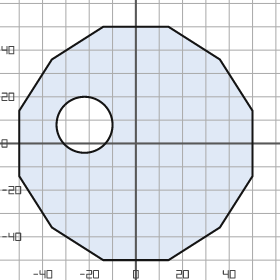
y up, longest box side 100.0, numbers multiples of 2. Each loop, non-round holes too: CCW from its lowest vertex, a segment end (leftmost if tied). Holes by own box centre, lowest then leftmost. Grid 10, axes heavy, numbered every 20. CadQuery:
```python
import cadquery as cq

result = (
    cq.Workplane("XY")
    .moveTo(-14.0, -50.0)
    .lineTo(14.0, -50.0)
    .lineTo(36.0, -36.0)
    .lineTo(50.0, -14.0)
    .lineTo(50.0, 14.0)
    .lineTo(36.0, 36.0)
    .lineTo(14.0, 50.0)
    .lineTo(-14.0, 50.0)
    .lineTo(-36.0, 36.0)
    .lineTo(-50.0, 14.0)
    .lineTo(-50.0, -14.0)
    .lineTo(-36.0, -36.0)
    .close()
    .moveTo(-22.0, 8.0)
    .circle(12.0)
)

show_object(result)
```